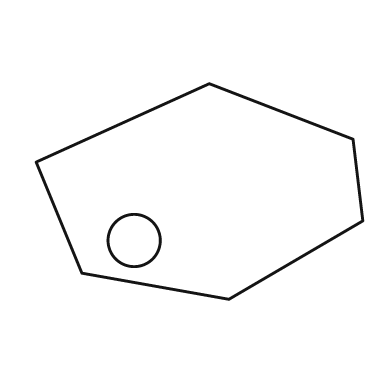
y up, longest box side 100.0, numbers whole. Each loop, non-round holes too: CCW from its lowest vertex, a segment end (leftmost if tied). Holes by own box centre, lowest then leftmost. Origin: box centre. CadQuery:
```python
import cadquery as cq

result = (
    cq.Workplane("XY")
    .moveTo(9.0, -33.0)
    .lineTo(50.0, -9.0)
    .lineTo(47.0, 16.0)
    .lineTo(3.0, 33.0)
    .lineTo(-50.0, 9.0)
    .lineTo(-36.0, -25.0)
    .close()
    .moveTo(-20.0, -15.0)
    .circle(8.0)
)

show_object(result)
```